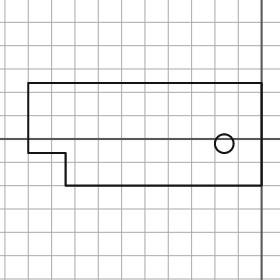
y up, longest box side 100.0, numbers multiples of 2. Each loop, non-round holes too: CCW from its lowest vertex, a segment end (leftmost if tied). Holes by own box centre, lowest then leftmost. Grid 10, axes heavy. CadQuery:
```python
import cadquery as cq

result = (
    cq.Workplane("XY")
    .moveTo(-84.0, -20.0)
    .lineTo(0.0, -20.0)
    .lineTo(0.0, 24.0)
    .lineTo(-100.0, 24.0)
    .lineTo(-100.0, -6.0)
    .lineTo(-84.0, -6.0)
    .close()
    .moveTo(-16.0, -2.0)
    .circle(4.0)
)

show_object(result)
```